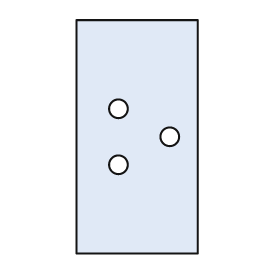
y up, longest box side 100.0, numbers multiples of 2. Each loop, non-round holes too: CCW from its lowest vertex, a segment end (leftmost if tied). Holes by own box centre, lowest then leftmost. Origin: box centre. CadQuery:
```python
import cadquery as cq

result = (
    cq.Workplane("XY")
    .moveTo(-26.0, -50.0)
    .lineTo(26.0, -50.0)
    .lineTo(26.0, 50.0)
    .lineTo(-26.0, 50.0)
    .close()
    .moveTo(-8.0, -12.0)
    .circle(4.0)
    .moveTo(14.0, 0.0)
    .circle(4.0)
    .moveTo(-8.0, 12.0)
    .circle(4.0)
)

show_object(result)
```